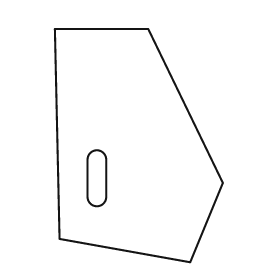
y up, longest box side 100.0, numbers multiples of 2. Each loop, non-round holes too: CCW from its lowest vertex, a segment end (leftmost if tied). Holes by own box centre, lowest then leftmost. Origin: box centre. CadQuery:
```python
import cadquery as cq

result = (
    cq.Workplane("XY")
    .moveTo(22.0, -50.0)
    .lineTo(36.0, -16.0)
    .lineTo(4.0, 50.0)
    .lineTo(-36.0, 50.0)
    .lineTo(-34.0, -40.0)
    .close()
    .moveTo(-22.0, -22.0)
    .threePointArc((-18.0, -26.0), (-14.0, -22.0))
    .lineTo(-14.0, -6.0)
    .threePointArc((-18.0, -2.0), (-22.0, -6.0))
    .close()
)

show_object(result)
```